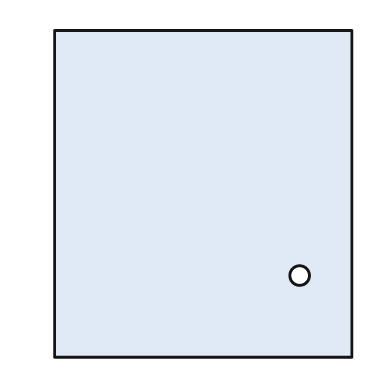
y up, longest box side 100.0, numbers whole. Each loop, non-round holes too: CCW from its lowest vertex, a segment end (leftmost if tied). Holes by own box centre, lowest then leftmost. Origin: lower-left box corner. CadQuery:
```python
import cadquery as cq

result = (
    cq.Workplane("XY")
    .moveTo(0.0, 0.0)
    .lineTo(91.0, 0.0)
    .lineTo(91.0, 100.0)
    .lineTo(0.0, 100.0)
    .close()
    .moveTo(75.0, 25.0)
    .circle(3.0)
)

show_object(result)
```